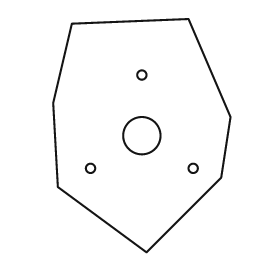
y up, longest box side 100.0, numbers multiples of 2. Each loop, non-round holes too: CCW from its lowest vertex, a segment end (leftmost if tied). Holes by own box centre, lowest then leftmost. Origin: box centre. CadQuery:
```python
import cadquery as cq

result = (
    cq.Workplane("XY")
    .moveTo(2.0, -50.0)
    .lineTo(34.0, -18.0)
    .lineTo(38.0, 8.0)
    .lineTo(20.0, 50.0)
    .lineTo(-30.0, 48.0)
    .lineTo(-38.0, 14.0)
    .lineTo(-36.0, -22.0)
    .close()
    .moveTo(-22.0, -14.0)
    .circle(2.0)
    .moveTo(22.0, -14.0)
    .circle(2.0)
    .moveTo(0.0, 0.0)
    .circle(8.0)
    .moveTo(0.0, 26.0)
    .circle(2.0)
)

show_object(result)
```